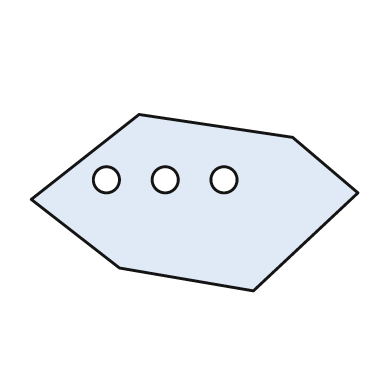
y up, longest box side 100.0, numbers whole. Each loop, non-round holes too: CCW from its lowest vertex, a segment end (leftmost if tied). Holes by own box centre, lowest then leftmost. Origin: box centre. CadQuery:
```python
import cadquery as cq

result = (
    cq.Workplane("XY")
    .moveTo(18.0, -27.0)
    .lineTo(50.0, 3.0)
    .lineTo(30.0, 20.0)
    .lineTo(-17.0, 27.0)
    .lineTo(-50.0, 1.0)
    .lineTo(-23.0, -20.0)
    .close()
    .moveTo(-27.0, 7.0)
    .circle(4.0)
    .moveTo(-9.0, 7.0)
    .circle(4.0)
    .moveTo(9.0, 7.0)
    .circle(4.0)
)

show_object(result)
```